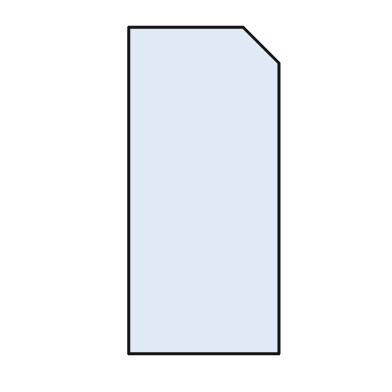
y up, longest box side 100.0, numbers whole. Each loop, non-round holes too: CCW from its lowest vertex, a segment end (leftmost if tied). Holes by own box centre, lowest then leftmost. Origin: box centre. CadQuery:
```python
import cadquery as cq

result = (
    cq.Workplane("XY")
    .moveTo(-23.0, -50.0)
    .lineTo(23.0, -50.0)
    .lineTo(23.0, 39.0)
    .lineTo(12.0, 50.0)
    .lineTo(-23.0, 50.0)
    .close()
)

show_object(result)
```